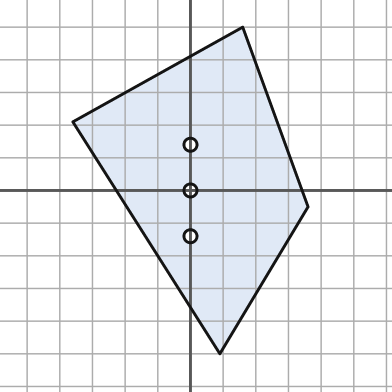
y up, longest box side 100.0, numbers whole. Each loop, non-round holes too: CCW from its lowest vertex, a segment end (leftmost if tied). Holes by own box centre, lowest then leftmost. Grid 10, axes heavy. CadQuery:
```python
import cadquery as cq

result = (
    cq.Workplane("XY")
    .moveTo(9.0, -50.0)
    .lineTo(36.0, -5.0)
    .lineTo(16.0, 50.0)
    .lineTo(-36.0, 21.0)
    .close()
    .moveTo(0.0, -14.0)
    .circle(2.0)
    .moveTo(0.0, 0.0)
    .circle(2.0)
    .moveTo(0.0, 14.0)
    .circle(2.0)
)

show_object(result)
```